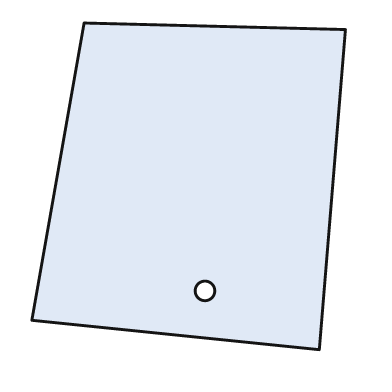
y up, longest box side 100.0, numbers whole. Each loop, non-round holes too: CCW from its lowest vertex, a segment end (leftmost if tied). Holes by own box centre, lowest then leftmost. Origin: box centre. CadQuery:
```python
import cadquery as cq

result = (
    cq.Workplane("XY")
    .moveTo(40.0, -50.0)
    .lineTo(48.0, 48.0)
    .lineTo(-32.0, 50.0)
    .lineTo(-48.0, -41.0)
    .close()
    .moveTo(5.0, -32.0)
    .circle(3.0)
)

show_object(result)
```